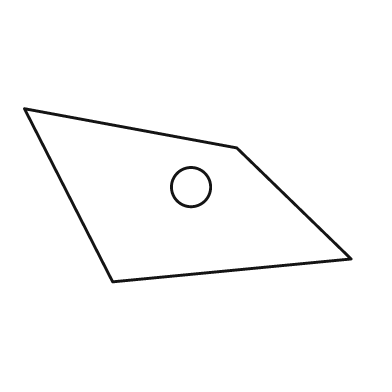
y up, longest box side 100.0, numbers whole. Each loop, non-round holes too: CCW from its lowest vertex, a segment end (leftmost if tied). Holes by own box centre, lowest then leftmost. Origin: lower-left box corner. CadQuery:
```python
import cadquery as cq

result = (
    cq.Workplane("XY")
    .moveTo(27.0, 0.0)
    .lineTo(100.0, 7.0)
    .lineTo(65.0, 41.0)
    .lineTo(0.0, 53.0)
    .close()
    .moveTo(51.0, 29.0)
    .circle(6.0)
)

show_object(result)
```